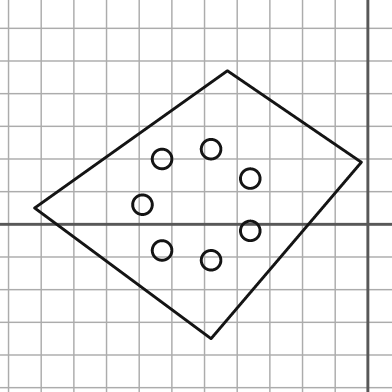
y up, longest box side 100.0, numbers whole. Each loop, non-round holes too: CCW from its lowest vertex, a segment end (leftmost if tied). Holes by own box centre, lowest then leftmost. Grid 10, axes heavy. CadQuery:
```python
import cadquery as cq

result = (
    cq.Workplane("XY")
    .moveTo(-48.0, -35.0)
    .lineTo(-2.0, 19.0)
    .lineTo(-43.0, 47.0)
    .lineTo(-102.0, 5.0)
    .close()
    .moveTo(-48.0, -11.0)
    .circle(3.0)
    .moveTo(-63.0, -8.0)
    .circle(3.0)
    .moveTo(-36.0, -2.0)
    .circle(3.0)
    .moveTo(-69.0, 6.0)
    .circle(3.0)
    .moveTo(-36.0, 14.0)
    .circle(3.0)
    .moveTo(-63.0, 20.0)
    .circle(3.0)
    .moveTo(-48.0, 23.0)
    .circle(3.0)
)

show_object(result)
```